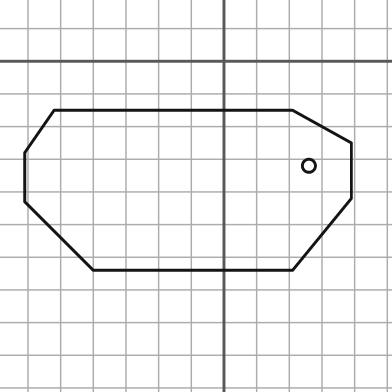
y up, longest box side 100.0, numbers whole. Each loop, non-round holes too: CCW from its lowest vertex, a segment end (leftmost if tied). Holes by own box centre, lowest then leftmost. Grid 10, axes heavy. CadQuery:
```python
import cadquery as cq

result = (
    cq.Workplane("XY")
    .moveTo(-40.0, -64.0)
    .lineTo(21.0, -64.0)
    .lineTo(39.0, -42.0)
    .lineTo(39.0, -25.0)
    .lineTo(21.0, -15.0)
    .lineTo(-52.0, -15.0)
    .lineTo(-61.0, -28.0)
    .lineTo(-61.0, -43.0)
    .close()
    .moveTo(26.0, -32.0)
    .circle(2.0)
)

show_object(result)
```